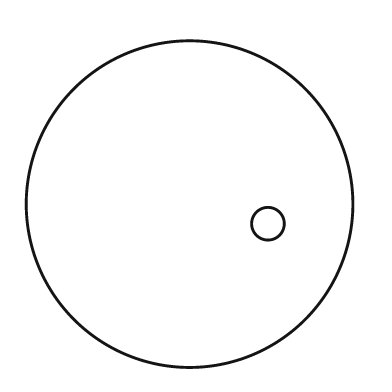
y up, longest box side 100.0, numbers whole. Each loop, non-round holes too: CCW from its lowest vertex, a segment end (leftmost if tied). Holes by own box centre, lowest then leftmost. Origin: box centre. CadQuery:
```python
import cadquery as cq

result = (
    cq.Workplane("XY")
    .moveTo(0.0, 0.0)
    .circle(50.0)
    .moveTo(24.0, -6.0)
    .circle(5.0)
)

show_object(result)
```